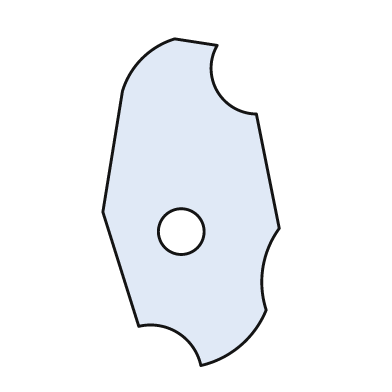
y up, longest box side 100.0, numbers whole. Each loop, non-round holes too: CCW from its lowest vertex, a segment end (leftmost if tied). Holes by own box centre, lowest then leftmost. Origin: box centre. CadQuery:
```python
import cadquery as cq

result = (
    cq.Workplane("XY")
    .moveTo(3.0, -50.0)
    .threePointArc((15.0, -44.0), (23.0, -33.0))
    .threePointArc((22.0, -20.0), (27.0, -8.0))
    .lineTo(20.0, 27.0)
    .threePointArc((8.0, 34.0), (8.0, 48.0))
    .lineTo(-5.0, 50.0)
    .threePointArc((-15.0, 44.0), (-21.0, 34.0))
    .lineTo(-27.0, -3.0)
    .lineTo(-16.0, -38.0)
    .threePointArc((-4.0, -40.0), (3.0, -50.0))
    .close()
    .moveTo(-3.0, -9.0)
    .circle(7.0)
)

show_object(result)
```